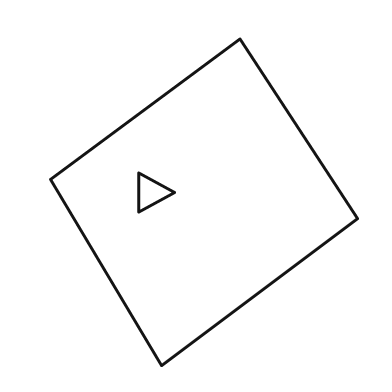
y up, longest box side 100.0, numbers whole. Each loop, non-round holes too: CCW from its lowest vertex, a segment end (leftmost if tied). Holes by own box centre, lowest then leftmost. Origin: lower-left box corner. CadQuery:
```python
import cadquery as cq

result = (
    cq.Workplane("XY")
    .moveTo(34.0, 0.0)
    .lineTo(94.0, 45.0)
    .lineTo(58.0, 100.0)
    .lineTo(0.0, 57.0)
    .close()
    .moveTo(27.0, 47.0)
    .lineTo(38.0, 53.0)
    .lineTo(27.0, 59.0)
    .close()
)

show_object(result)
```